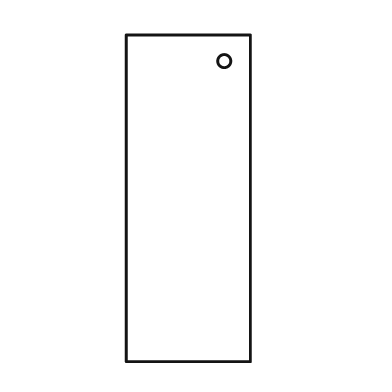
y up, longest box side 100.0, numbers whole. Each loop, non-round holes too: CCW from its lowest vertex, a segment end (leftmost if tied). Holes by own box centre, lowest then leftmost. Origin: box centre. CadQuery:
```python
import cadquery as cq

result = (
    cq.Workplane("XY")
    .moveTo(-19.0, -50.0)
    .lineTo(19.0, -50.0)
    .lineTo(19.0, 50.0)
    .lineTo(-19.0, 50.0)
    .close()
    .moveTo(11.0, 42.0)
    .circle(2.0)
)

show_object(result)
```